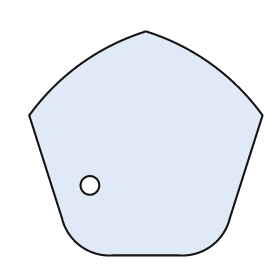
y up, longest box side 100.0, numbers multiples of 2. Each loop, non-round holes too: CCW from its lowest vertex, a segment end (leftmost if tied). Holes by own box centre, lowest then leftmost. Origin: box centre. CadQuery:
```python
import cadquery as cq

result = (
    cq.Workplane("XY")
    .moveTo(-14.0, -48.0)
    .lineTo(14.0, -48.0)
    .threePointArc((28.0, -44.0), (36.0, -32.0))
    .lineTo(50.0, 12.0)
    .threePointArc((28.0, 34.0), (0.0, 48.0))
    .threePointArc((-28.0, 34.0), (-50.0, 12.0))
    .lineTo(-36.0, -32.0)
    .threePointArc((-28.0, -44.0), (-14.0, -48.0))
    .close()
    .moveTo(-24.0, -18.0)
    .circle(4.0)
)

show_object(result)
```